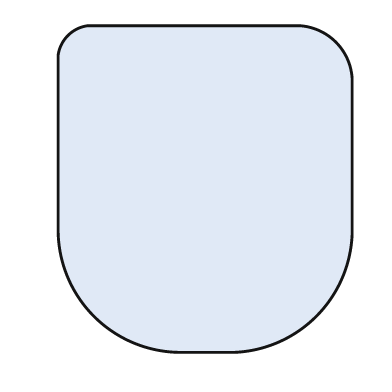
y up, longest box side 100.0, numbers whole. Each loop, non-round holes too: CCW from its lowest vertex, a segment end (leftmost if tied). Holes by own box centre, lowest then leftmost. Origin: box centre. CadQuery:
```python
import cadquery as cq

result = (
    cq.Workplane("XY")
    .moveTo(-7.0, -50.0)
    .lineTo(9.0, -50.0)
    .threePointArc((34.0, -39.0), (45.0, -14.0))
    .lineTo(45.0, 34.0)
    .threePointArc((40.0, 45.0), (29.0, 50.0))
    .lineTo(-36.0, 50.0)
    .threePointArc((-42.0, 47.0), (-45.0, 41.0))
    .lineTo(-45.0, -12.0)
    .threePointArc((-34.0, -39.0), (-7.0, -50.0))
    .close()
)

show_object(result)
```